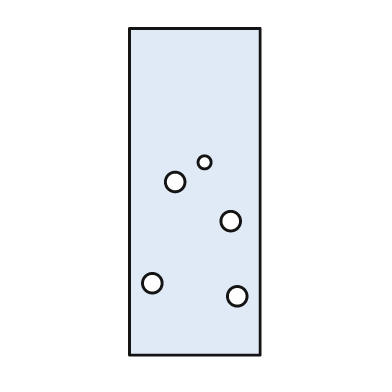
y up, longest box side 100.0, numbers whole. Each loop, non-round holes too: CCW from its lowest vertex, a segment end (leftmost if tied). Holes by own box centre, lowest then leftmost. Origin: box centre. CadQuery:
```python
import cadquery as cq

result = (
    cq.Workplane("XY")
    .moveTo(-20.0, -50.0)
    .lineTo(20.0, -50.0)
    .lineTo(20.0, 50.0)
    .lineTo(-20.0, 50.0)
    .close()
    .moveTo(13.0, -32.0)
    .circle(3.0)
    .moveTo(-13.0, -28.0)
    .circle(3.0)
    .moveTo(11.0, -9.0)
    .circle(3.0)
    .moveTo(-6.0, 3.0)
    .circle(3.0)
    .moveTo(3.0, 9.0)
    .circle(2.0)
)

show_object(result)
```